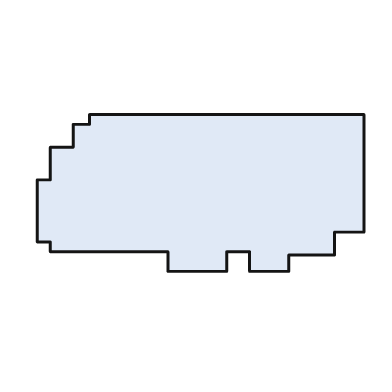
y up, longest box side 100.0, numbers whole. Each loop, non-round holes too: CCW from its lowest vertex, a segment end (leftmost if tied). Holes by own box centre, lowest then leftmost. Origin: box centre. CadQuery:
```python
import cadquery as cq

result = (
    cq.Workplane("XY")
    .moveTo(-10.0, -24.0)
    .lineTo(8.0, -24.0)
    .lineTo(8.0, -18.0)
    .lineTo(15.0, -18.0)
    .lineTo(15.0, -24.0)
    .lineTo(27.0, -24.0)
    .lineTo(27.0, -19.0)
    .lineTo(41.0, -19.0)
    .lineTo(41.0, -12.0)
    .lineTo(50.0, -12.0)
    .lineTo(50.0, 24.0)
    .lineTo(-34.0, 24.0)
    .lineTo(-34.0, 21.0)
    .lineTo(-39.0, 21.0)
    .lineTo(-39.0, 14.0)
    .lineTo(-46.0, 14.0)
    .lineTo(-46.0, 4.0)
    .lineTo(-50.0, 4.0)
    .lineTo(-50.0, -15.0)
    .lineTo(-46.0, -15.0)
    .lineTo(-46.0, -18.0)
    .lineTo(-10.0, -18.0)
    .close()
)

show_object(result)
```